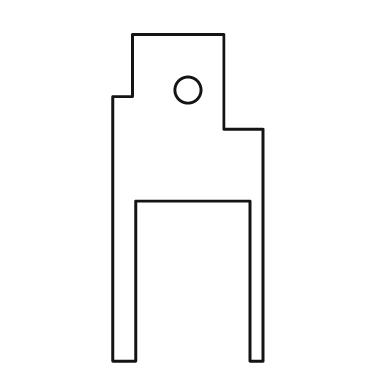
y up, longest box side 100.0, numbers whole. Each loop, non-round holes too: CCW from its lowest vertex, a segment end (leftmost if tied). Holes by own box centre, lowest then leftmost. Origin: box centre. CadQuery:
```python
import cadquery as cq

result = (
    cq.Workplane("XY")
    .moveTo(-23.0, -50.0)
    .lineTo(-16.0, -50.0)
    .lineTo(-16.0, -1.0)
    .lineTo(19.0, -1.0)
    .lineTo(19.0, -50.0)
    .lineTo(23.0, -50.0)
    .lineTo(23.0, 21.0)
    .lineTo(11.0, 21.0)
    .lineTo(11.0, 50.0)
    .lineTo(-17.0, 50.0)
    .lineTo(-17.0, 31.0)
    .lineTo(-23.0, 31.0)
    .close()
    .moveTo(0.0, 33.0)
    .circle(4.0)
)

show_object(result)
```